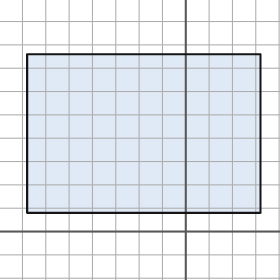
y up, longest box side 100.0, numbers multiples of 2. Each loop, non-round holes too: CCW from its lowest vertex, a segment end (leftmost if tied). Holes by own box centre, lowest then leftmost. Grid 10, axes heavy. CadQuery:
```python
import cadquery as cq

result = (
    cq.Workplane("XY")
    .moveTo(-68.0, 8.0)
    .lineTo(32.0, 8.0)
    .lineTo(32.0, 76.0)
    .lineTo(-68.0, 76.0)
    .close()
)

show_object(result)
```